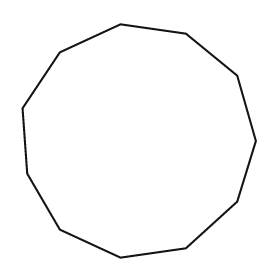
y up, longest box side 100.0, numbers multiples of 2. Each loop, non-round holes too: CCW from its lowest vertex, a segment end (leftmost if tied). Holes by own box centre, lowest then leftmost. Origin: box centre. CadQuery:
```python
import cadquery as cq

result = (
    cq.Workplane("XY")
    .moveTo(-8.0, -50.0)
    .lineTo(20.0, -46.0)
    .lineTo(42.0, -26.0)
    .lineTo(50.0, 0.0)
    .lineTo(42.0, 28.0)
    .lineTo(20.0, 46.0)
    .lineTo(-8.0, 50.0)
    .lineTo(-34.0, 38.0)
    .lineTo(-50.0, 14.0)
    .lineTo(-48.0, -14.0)
    .lineTo(-34.0, -38.0)
    .close()
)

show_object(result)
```